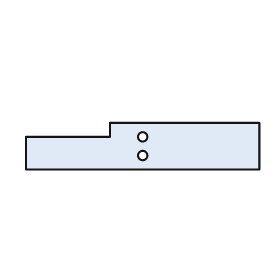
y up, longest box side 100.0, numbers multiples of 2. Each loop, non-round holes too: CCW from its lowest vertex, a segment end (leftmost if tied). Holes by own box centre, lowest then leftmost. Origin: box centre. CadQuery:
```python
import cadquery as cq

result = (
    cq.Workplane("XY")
    .moveTo(-50.0, -10.0)
    .lineTo(50.0, -10.0)
    .lineTo(50.0, 10.0)
    .lineTo(-14.0, 10.0)
    .lineTo(-14.0, 4.0)
    .lineTo(-50.0, 4.0)
    .close()
    .moveTo(0.0, -4.0)
    .circle(2.0)
    .moveTo(0.0, 4.0)
    .circle(2.0)
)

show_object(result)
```